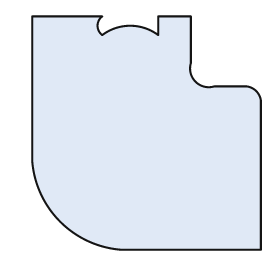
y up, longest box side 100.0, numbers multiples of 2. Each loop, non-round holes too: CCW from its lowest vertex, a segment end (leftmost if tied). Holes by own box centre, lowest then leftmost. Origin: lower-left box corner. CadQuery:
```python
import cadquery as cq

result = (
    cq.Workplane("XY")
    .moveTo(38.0, 0.0)
    .lineTo(98.0, 0.0)
    .lineTo(98.0, 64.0)
    .threePointArc((96.0, 68.0), (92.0, 70.0))
    .lineTo(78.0, 70.0)
    .threePointArc((70.0, 72.0), (68.0, 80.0))
    .lineTo(68.0, 100.0)
    .lineTo(54.0, 100.0)
    .lineTo(54.0, 92.0)
    .threePointArc((42.0, 96.0), (30.0, 92.0))
    .threePointArc((28.0, 96.0), (30.0, 100.0))
    .lineTo(0.0, 100.0)
    .lineTo(0.0, 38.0)
    .threePointArc((12.0, 12.0), (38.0, 0.0))
    .close()
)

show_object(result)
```